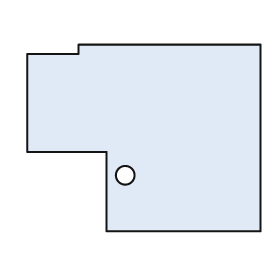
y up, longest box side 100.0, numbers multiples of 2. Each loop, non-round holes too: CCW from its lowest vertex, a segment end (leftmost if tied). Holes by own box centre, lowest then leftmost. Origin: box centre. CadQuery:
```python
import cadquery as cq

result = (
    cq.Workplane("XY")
    .moveTo(-16.0, -40.0)
    .lineTo(50.0, -40.0)
    .lineTo(50.0, 40.0)
    .lineTo(-28.0, 40.0)
    .lineTo(-28.0, 36.0)
    .lineTo(-50.0, 36.0)
    .lineTo(-50.0, -6.0)
    .lineTo(-16.0, -6.0)
    .close()
    .moveTo(-8.0, -16.0)
    .circle(4.0)
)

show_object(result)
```